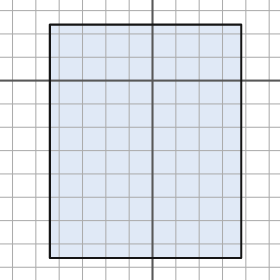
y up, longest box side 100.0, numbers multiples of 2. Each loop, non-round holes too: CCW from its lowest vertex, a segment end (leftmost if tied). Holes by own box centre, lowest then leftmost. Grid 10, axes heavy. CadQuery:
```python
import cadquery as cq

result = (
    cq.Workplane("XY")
    .moveTo(-44.0, -76.0)
    .lineTo(38.0, -76.0)
    .lineTo(38.0, 24.0)
    .lineTo(-44.0, 24.0)
    .close()
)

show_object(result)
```